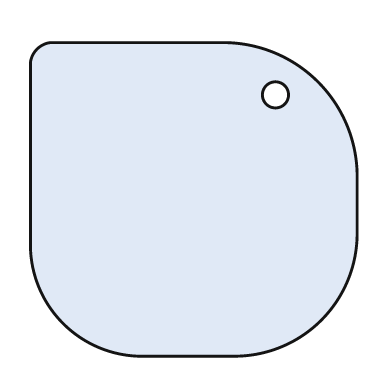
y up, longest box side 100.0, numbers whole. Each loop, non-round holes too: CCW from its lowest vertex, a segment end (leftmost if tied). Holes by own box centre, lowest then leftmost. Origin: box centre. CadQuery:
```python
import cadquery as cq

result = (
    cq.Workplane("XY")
    .moveTo(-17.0, -48.0)
    .lineTo(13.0, -48.0)
    .threePointArc((39.0, -37.0), (50.0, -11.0))
    .lineTo(50.0, 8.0)
    .threePointArc((38.0, 36.0), (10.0, 48.0))
    .lineTo(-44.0, 48.0)
    .threePointArc((-48.0, 46.0), (-50.0, 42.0))
    .lineTo(-50.0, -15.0)
    .threePointArc((-40.0, -38.0), (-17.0, -48.0))
    .close()
    .moveTo(25.0, 32.0)
    .circle(4.0)
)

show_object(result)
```